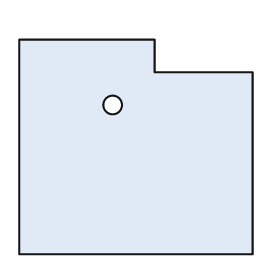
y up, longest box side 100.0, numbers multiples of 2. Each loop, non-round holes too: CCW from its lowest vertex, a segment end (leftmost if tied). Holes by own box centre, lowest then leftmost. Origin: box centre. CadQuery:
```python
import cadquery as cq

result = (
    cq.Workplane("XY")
    .moveTo(-50.0, -46.0)
    .lineTo(50.0, -46.0)
    .lineTo(50.0, 32.0)
    .lineTo(8.0, 32.0)
    .lineTo(8.0, 46.0)
    .lineTo(-50.0, 46.0)
    .close()
    .moveTo(-10.0, 18.0)
    .circle(4.0)
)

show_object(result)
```